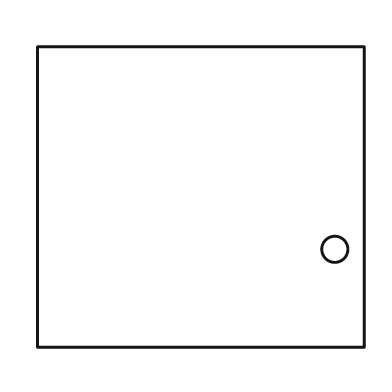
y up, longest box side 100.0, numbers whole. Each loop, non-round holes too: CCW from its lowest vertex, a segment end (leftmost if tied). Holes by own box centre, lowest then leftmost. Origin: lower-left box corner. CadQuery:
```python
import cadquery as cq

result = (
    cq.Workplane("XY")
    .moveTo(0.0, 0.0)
    .lineTo(100.0, 0.0)
    .lineTo(100.0, 92.0)
    .lineTo(0.0, 92.0)
    .close()
    .moveTo(91.0, 30.0)
    .circle(4.0)
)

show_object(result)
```